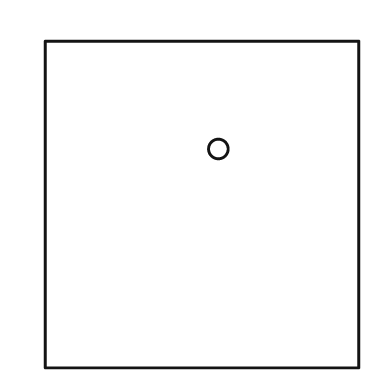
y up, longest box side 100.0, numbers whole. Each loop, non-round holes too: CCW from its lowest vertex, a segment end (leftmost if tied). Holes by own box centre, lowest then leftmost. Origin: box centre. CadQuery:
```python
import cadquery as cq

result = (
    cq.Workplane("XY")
    .moveTo(-48.0, -50.0)
    .lineTo(48.0, -50.0)
    .lineTo(48.0, 50.0)
    .lineTo(-48.0, 50.0)
    .close()
    .moveTo(5.0, 17.0)
    .circle(3.0)
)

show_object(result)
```